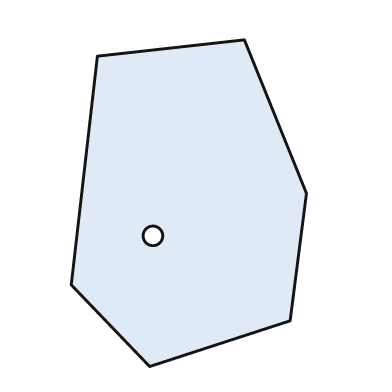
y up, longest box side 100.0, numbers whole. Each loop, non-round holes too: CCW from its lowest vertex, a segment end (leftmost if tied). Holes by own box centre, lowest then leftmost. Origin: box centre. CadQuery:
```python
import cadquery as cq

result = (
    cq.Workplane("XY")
    .moveTo(-12.0, -50.0)
    .lineTo(31.0, -36.0)
    .lineTo(36.0, 3.0)
    .lineTo(17.0, 50.0)
    .lineTo(-28.0, 45.0)
    .lineTo(-36.0, -25.0)
    .close()
    .moveTo(-11.0, -10.0)
    .circle(3.0)
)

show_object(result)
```